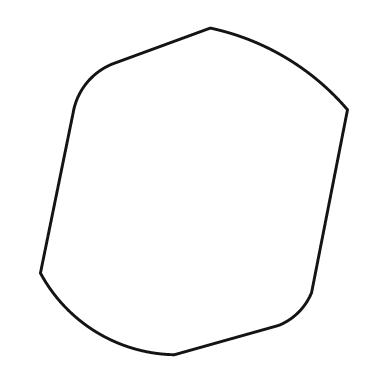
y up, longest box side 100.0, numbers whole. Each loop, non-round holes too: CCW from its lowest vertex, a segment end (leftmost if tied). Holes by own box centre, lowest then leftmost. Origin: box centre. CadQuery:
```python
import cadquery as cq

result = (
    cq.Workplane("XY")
    .moveTo(-6.0, -50.0)
    .lineTo(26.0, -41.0)
    .threePointArc((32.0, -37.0), (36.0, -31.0))
    .lineTo(47.0, 25.0)
    .threePointArc((28.0, 41.0), (5.0, 50.0))
    .lineTo(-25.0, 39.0)
    .threePointArc((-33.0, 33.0), (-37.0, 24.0))
    .lineTo(-47.0, -25.0)
    .threePointArc((-30.0, -43.0), (-6.0, -50.0))
    .close()
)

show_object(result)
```